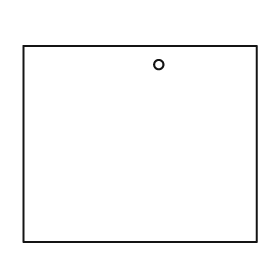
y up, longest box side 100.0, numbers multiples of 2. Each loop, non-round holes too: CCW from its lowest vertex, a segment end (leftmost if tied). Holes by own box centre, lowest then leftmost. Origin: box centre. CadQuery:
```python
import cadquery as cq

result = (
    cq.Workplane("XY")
    .moveTo(-50.0, -42.0)
    .lineTo(50.0, -42.0)
    .lineTo(50.0, 42.0)
    .lineTo(-50.0, 42.0)
    .close()
    .moveTo(8.0, 34.0)
    .circle(2.0)
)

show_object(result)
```